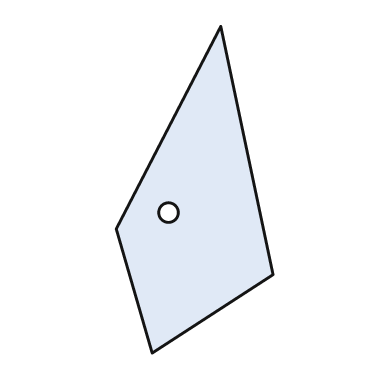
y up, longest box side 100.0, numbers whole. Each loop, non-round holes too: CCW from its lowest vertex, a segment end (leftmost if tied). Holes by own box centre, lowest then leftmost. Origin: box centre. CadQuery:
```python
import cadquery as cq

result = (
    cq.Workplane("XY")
    .moveTo(-13.0, -50.0)
    .lineTo(24.0, -26.0)
    .lineTo(8.0, 50.0)
    .lineTo(-24.0, -12.0)
    .close()
    .moveTo(-8.0, -7.0)
    .circle(3.0)
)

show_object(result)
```